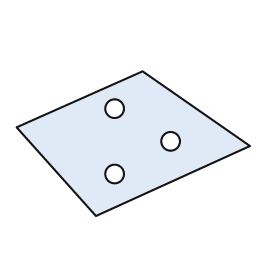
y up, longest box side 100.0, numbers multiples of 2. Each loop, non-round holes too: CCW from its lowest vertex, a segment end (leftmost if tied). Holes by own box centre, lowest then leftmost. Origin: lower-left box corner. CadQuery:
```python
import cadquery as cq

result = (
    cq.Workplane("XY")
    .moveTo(34.0, 0.0)
    .lineTo(100.0, 30.0)
    .lineTo(54.0, 62.0)
    .lineTo(0.0, 38.0)
    .close()
    .moveTo(42.0, 18.0)
    .circle(4.0)
    .moveTo(66.0, 32.0)
    .circle(4.0)
    .moveTo(42.0, 46.0)
    .circle(4.0)
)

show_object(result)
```